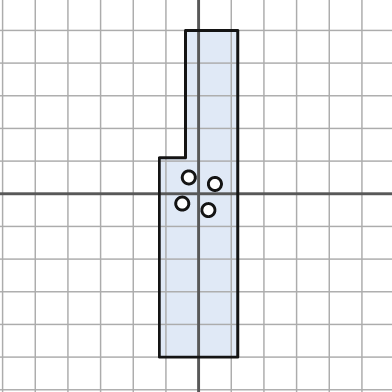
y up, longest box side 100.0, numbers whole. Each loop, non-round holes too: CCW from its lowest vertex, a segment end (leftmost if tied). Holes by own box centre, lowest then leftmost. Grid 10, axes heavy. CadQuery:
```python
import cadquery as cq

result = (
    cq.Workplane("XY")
    .moveTo(-12.0, -50.0)
    .lineTo(12.0, -50.0)
    .lineTo(12.0, 50.0)
    .lineTo(-4.0, 50.0)
    .lineTo(-4.0, 11.0)
    .lineTo(-12.0, 11.0)
    .close()
    .moveTo(3.0, -5.0)
    .circle(2.0)
    .moveTo(-5.0, -3.0)
    .circle(2.0)
    .moveTo(5.0, 3.0)
    .circle(2.0)
    .moveTo(-3.0, 5.0)
    .circle(2.0)
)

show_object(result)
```